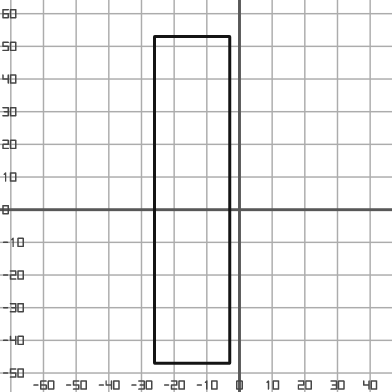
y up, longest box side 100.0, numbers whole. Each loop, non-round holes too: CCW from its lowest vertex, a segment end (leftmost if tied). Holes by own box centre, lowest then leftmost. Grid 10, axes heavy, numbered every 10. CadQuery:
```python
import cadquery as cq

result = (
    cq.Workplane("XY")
    .moveTo(-26.0, -47.0)
    .lineTo(-3.0, -47.0)
    .lineTo(-3.0, 53.0)
    .lineTo(-26.0, 53.0)
    .close()
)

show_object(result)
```